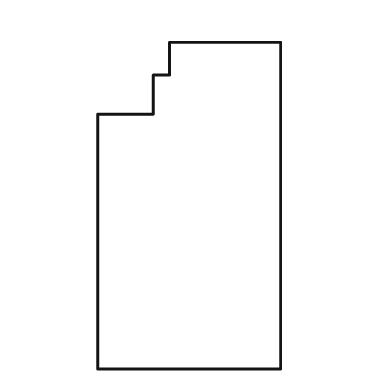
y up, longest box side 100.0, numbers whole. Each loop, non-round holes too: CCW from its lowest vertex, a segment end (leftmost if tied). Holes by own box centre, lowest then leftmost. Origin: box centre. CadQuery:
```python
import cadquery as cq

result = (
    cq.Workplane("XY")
    .moveTo(-28.0, -50.0)
    .lineTo(28.0, -50.0)
    .lineTo(28.0, 50.0)
    .lineTo(-6.0, 50.0)
    .lineTo(-6.0, 40.0)
    .lineTo(-11.0, 40.0)
    .lineTo(-11.0, 28.0)
    .lineTo(-28.0, 28.0)
    .close()
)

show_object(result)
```